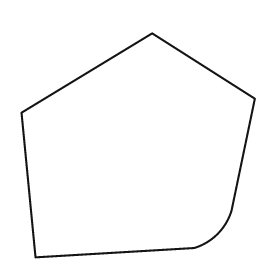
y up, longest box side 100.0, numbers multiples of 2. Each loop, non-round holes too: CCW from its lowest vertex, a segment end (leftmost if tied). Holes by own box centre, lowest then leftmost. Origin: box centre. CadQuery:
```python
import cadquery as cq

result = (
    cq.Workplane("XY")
    .moveTo(-44.0, -48.0)
    .lineTo(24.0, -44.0)
    .threePointArc((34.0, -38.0), (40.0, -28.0))
    .lineTo(50.0, 20.0)
    .lineTo(6.0, 48.0)
    .lineTo(-50.0, 14.0)
    .close()
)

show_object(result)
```